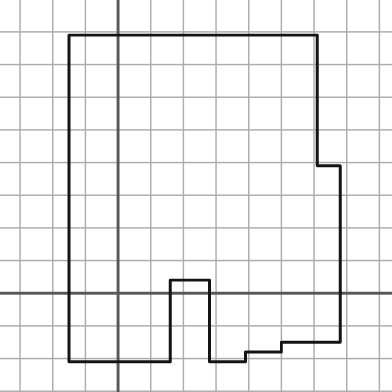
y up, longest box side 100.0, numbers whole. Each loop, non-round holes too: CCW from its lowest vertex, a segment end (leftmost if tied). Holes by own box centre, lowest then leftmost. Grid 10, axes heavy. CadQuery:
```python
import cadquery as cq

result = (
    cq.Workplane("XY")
    .moveTo(-15.0, -21.0)
    .lineTo(16.0, -21.0)
    .lineTo(16.0, 4.0)
    .lineTo(28.0, 4.0)
    .lineTo(28.0, -21.0)
    .lineTo(39.0, -21.0)
    .lineTo(39.0, -18.0)
    .lineTo(50.0, -18.0)
    .lineTo(50.0, -15.0)
    .lineTo(68.0, -15.0)
    .lineTo(68.0, 39.0)
    .lineTo(61.0, 39.0)
    .lineTo(61.0, 79.0)
    .lineTo(-15.0, 79.0)
    .close()
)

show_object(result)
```